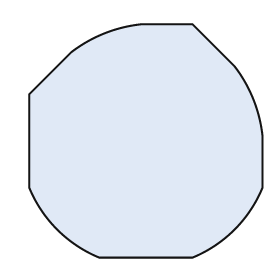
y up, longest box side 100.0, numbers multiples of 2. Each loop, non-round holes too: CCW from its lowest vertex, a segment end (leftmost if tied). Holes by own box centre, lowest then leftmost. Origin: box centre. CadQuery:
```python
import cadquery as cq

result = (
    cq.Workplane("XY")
    .moveTo(-20.0, -50.0)
    .lineTo(20.0, -50.0)
    .threePointArc((38.0, -38.0), (50.0, -20.0))
    .lineTo(50.0, 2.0)
    .threePointArc((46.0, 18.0), (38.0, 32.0))
    .lineTo(20.0, 50.0)
    .lineTo(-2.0, 50.0)
    .threePointArc((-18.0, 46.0), (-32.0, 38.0))
    .lineTo(-50.0, 20.0)
    .lineTo(-50.0, -20.0)
    .threePointArc((-38.0, -38.0), (-20.0, -50.0))
    .close()
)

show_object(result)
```